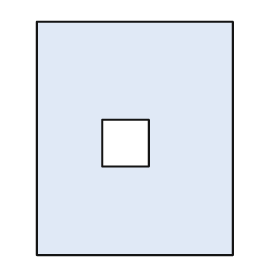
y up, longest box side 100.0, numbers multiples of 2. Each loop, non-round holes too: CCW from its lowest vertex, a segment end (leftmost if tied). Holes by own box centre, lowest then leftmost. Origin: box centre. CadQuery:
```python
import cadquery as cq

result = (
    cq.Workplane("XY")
    .moveTo(-42.0, -50.0)
    .lineTo(42.0, -50.0)
    .lineTo(42.0, 50.0)
    .lineTo(-42.0, 50.0)
    .close()
    .moveTo(-14.0, -12.0)
    .lineTo(6.0, -12.0)
    .lineTo(6.0, 8.0)
    .lineTo(-14.0, 8.0)
    .close()
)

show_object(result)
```